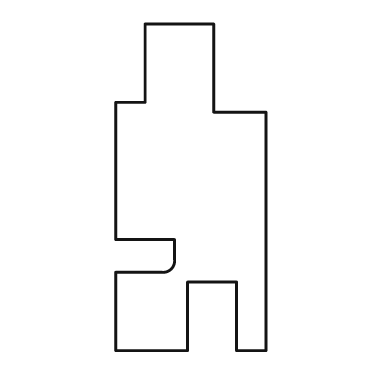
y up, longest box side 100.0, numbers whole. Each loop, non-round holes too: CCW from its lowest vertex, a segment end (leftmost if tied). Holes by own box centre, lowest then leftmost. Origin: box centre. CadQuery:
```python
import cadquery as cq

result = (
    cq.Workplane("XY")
    .moveTo(-23.0, -50.0)
    .lineTo(-1.0, -50.0)
    .lineTo(-1.0, -29.0)
    .lineTo(14.0, -29.0)
    .lineTo(14.0, -50.0)
    .lineTo(23.0, -50.0)
    .lineTo(23.0, 23.0)
    .lineTo(7.0, 23.0)
    .lineTo(7.0, 50.0)
    .lineTo(-14.0, 50.0)
    .lineTo(-14.0, 26.0)
    .lineTo(-23.0, 26.0)
    .lineTo(-23.0, -16.0)
    .lineTo(-5.0, -16.0)
    .lineTo(-5.0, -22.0)
    .threePointArc((-6.0, -25.0), (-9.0, -26.0))
    .lineTo(-23.0, -26.0)
    .close()
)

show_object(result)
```